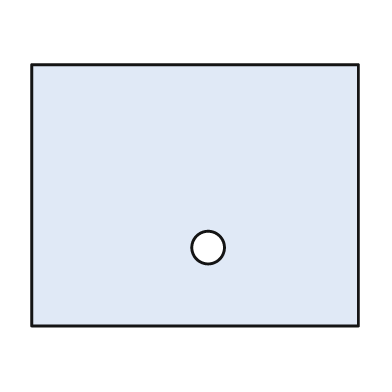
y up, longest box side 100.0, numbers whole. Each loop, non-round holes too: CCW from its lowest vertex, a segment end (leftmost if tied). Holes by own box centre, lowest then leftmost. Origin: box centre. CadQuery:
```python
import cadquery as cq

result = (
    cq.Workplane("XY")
    .moveTo(-50.0, -40.0)
    .lineTo(50.0, -40.0)
    .lineTo(50.0, 40.0)
    .lineTo(-50.0, 40.0)
    .close()
    .moveTo(4.0, -16.0)
    .circle(5.0)
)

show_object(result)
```